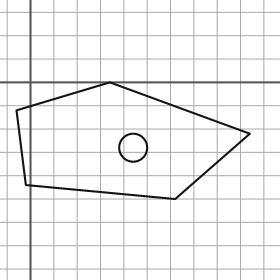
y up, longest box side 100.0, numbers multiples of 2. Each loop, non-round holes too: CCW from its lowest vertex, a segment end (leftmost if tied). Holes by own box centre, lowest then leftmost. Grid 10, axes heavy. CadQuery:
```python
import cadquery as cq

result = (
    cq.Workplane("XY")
    .moveTo(62.0, -50.0)
    .lineTo(94.0, -22.0)
    .lineTo(34.0, 0.0)
    .lineTo(-6.0, -12.0)
    .lineTo(-2.0, -44.0)
    .close()
    .moveTo(44.0, -28.0)
    .circle(6.0)
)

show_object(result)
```